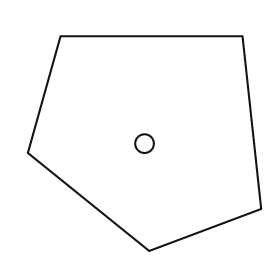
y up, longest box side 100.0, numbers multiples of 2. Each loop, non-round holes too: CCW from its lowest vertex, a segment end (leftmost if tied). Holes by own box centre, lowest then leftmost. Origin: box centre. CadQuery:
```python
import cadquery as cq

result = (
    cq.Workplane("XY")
    .moveTo(2.0, -46.0)
    .lineTo(50.0, -28.0)
    .lineTo(42.0, 46.0)
    .lineTo(-36.0, 46.0)
    .lineTo(-50.0, -4.0)
    .close()
    .moveTo(0.0, 0.0)
    .circle(4.0)
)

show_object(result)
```